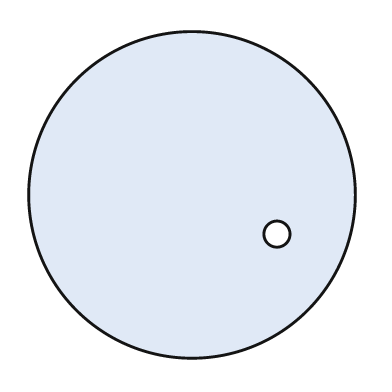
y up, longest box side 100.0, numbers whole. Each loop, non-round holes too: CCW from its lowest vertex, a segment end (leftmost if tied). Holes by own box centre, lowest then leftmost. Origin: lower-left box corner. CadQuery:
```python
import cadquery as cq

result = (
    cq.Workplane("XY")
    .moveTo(50.0, 50.0)
    .circle(50.0)
    .moveTo(76.0, 38.0)
    .circle(4.0)
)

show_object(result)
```